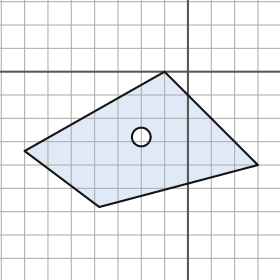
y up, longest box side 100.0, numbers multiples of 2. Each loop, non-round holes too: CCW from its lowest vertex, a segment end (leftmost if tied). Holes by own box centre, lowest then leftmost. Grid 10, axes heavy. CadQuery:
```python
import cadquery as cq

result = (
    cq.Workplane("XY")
    .moveTo(-38.0, -58.0)
    .lineTo(30.0, -40.0)
    .lineTo(-10.0, 0.0)
    .lineTo(-70.0, -34.0)
    .close()
    .moveTo(-20.0, -28.0)
    .circle(4.0)
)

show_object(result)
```